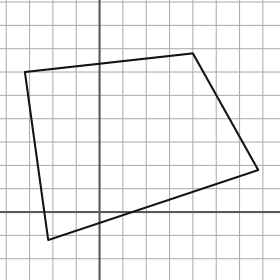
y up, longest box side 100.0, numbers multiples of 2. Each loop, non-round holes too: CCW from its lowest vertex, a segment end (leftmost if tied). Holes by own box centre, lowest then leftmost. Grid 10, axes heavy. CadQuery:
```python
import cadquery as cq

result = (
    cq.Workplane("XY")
    .moveTo(-22.0, -12.0)
    .lineTo(68.0, 18.0)
    .lineTo(40.0, 68.0)
    .lineTo(-32.0, 60.0)
    .close()
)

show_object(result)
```